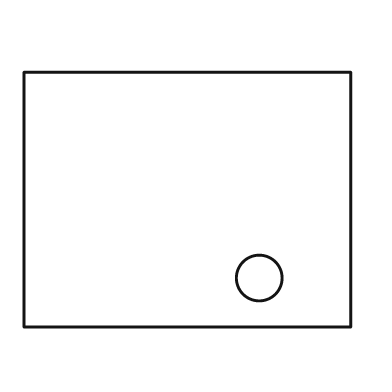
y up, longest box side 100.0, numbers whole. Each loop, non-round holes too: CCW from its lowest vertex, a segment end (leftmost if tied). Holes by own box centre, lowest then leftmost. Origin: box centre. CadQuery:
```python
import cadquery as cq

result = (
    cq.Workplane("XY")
    .moveTo(-50.0, -39.0)
    .lineTo(50.0, -39.0)
    .lineTo(50.0, 39.0)
    .lineTo(-50.0, 39.0)
    .close()
    .moveTo(22.0, -24.0)
    .circle(7.0)
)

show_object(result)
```